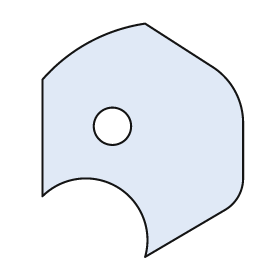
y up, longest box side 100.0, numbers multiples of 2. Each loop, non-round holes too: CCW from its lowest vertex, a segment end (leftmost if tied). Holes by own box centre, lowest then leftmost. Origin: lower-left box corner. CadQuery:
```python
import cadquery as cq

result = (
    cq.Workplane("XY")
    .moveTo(44.0, 0.0)
    .lineTo(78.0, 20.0)
    .threePointArc((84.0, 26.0), (86.0, 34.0))
    .lineTo(86.0, 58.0)
    .threePointArc((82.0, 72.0), (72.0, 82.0))
    .lineTo(44.0, 100.0)
    .threePointArc((20.0, 92.0), (0.0, 76.0))
    .lineTo(0.0, 26.0)
    .threePointArc((32.0, 30.0), (44.0, 0.0))
    .close()
    .moveTo(30.0, 56.0)
    .circle(8.0)
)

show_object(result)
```